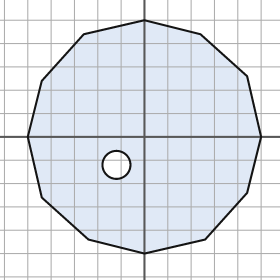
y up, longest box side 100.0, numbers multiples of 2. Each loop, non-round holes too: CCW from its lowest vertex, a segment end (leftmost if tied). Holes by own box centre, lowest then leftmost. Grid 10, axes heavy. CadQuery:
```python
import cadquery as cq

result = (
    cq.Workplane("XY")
    .moveTo(0.0, -50.0)
    .lineTo(26.0, -44.0)
    .lineTo(44.0, -24.0)
    .lineTo(50.0, 0.0)
    .lineTo(44.0, 26.0)
    .lineTo(24.0, 44.0)
    .lineTo(0.0, 50.0)
    .lineTo(-26.0, 44.0)
    .lineTo(-44.0, 24.0)
    .lineTo(-50.0, 0.0)
    .lineTo(-44.0, -26.0)
    .lineTo(-24.0, -44.0)
    .close()
    .moveTo(-12.0, -12.0)
    .circle(6.0)
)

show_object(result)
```